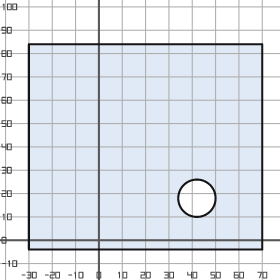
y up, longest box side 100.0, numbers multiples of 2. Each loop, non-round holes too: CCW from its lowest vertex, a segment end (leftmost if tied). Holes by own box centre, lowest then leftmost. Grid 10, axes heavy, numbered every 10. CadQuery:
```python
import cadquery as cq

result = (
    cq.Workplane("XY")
    .moveTo(-30.0, -4.0)
    .lineTo(70.0, -4.0)
    .lineTo(70.0, 84.0)
    .lineTo(-30.0, 84.0)
    .close()
    .moveTo(42.0, 18.0)
    .circle(8.0)
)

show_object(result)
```